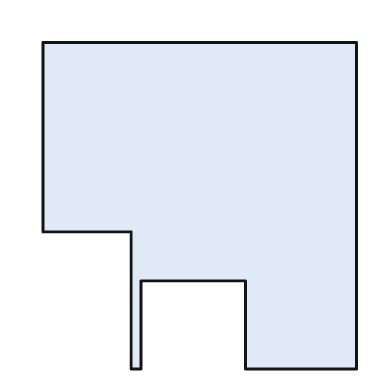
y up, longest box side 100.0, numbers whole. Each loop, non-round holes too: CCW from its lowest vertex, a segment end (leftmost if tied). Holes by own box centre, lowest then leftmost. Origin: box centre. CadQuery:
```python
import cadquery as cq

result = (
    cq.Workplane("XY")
    .moveTo(-21.0, -50.0)
    .lineTo(-18.0, -50.0)
    .lineTo(-18.0, -23.0)
    .lineTo(14.0, -23.0)
    .lineTo(14.0, -50.0)
    .lineTo(48.0, -50.0)
    .lineTo(48.0, 50.0)
    .lineTo(-48.0, 50.0)
    .lineTo(-48.0, -8.0)
    .lineTo(-21.0, -8.0)
    .close()
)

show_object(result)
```